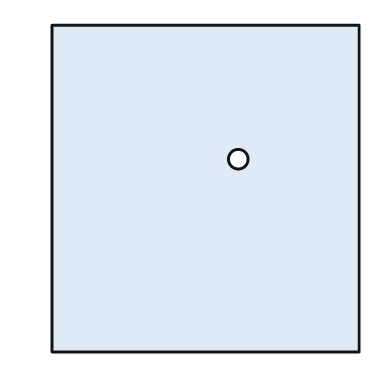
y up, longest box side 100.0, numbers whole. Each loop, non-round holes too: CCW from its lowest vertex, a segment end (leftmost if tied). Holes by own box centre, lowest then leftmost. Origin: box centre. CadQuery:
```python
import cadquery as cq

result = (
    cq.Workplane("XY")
    .moveTo(-47.0, -50.0)
    .lineTo(47.0, -50.0)
    .lineTo(47.0, 50.0)
    .lineTo(-47.0, 50.0)
    .close()
    .moveTo(10.0, 9.0)
    .circle(3.0)
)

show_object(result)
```